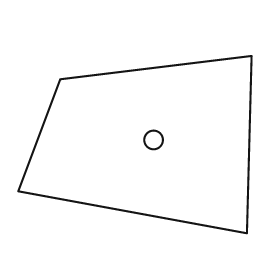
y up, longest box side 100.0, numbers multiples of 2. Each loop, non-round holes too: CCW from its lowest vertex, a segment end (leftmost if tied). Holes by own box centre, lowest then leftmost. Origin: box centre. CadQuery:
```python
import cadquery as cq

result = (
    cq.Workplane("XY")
    .moveTo(48.0, -38.0)
    .lineTo(50.0, 38.0)
    .lineTo(-32.0, 28.0)
    .lineTo(-50.0, -20.0)
    .close()
    .moveTo(8.0, 2.0)
    .circle(4.0)
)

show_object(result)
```